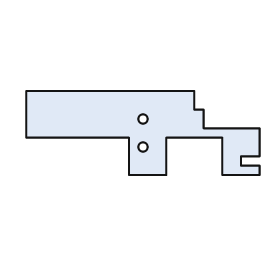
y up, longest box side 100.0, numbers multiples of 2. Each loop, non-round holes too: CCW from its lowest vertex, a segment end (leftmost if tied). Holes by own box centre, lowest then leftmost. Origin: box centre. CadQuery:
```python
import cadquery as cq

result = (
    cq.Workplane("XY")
    .moveTo(-6.0, -18.0)
    .lineTo(10.0, -18.0)
    .lineTo(10.0, -2.0)
    .lineTo(34.0, -2.0)
    .lineTo(34.0, -18.0)
    .lineTo(50.0, -18.0)
    .lineTo(50.0, -14.0)
    .lineTo(42.0, -14.0)
    .lineTo(42.0, -10.0)
    .lineTo(50.0, -10.0)
    .lineTo(50.0, 2.0)
    .lineTo(26.0, 2.0)
    .lineTo(26.0, 10.0)
    .lineTo(22.0, 10.0)
    .lineTo(22.0, 18.0)
    .lineTo(-50.0, 18.0)
    .lineTo(-50.0, -2.0)
    .lineTo(-6.0, -2.0)
    .close()
    .moveTo(0.0, -6.0)
    .circle(2.0)
    .moveTo(0.0, 6.0)
    .circle(2.0)
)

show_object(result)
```